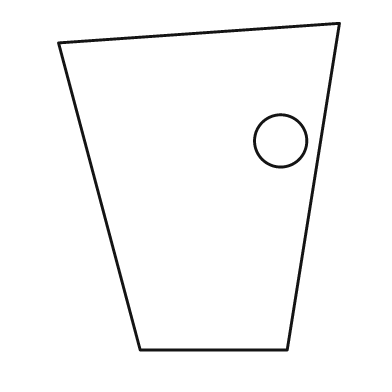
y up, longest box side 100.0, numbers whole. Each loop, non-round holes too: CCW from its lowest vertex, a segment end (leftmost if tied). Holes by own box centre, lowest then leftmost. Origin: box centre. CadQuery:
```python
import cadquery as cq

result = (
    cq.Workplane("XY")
    .moveTo(-18.0, -50.0)
    .lineTo(27.0, -50.0)
    .lineTo(43.0, 50.0)
    .lineTo(-43.0, 44.0)
    .close()
    .moveTo(25.0, 14.0)
    .circle(8.0)
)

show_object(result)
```